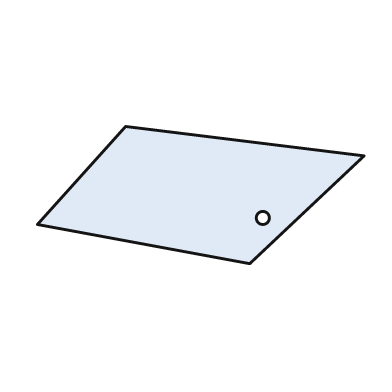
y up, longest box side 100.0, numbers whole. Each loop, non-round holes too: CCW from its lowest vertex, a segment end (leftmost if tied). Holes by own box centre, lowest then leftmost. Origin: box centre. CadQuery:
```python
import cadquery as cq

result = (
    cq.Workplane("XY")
    .moveTo(15.0, -21.0)
    .lineTo(50.0, 12.0)
    .lineTo(-23.0, 21.0)
    .lineTo(-50.0, -9.0)
    .close()
    .moveTo(19.0, -7.0)
    .circle(2.0)
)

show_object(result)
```